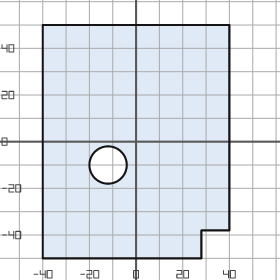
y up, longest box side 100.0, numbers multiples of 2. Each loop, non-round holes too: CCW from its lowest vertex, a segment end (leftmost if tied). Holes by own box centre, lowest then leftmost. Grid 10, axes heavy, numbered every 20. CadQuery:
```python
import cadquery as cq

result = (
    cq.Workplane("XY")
    .moveTo(-40.0, -50.0)
    .lineTo(28.0, -50.0)
    .lineTo(28.0, -38.0)
    .lineTo(40.0, -38.0)
    .lineTo(40.0, 50.0)
    .lineTo(-40.0, 50.0)
    .close()
    .moveTo(-12.0, -10.0)
    .circle(8.0)
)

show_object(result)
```